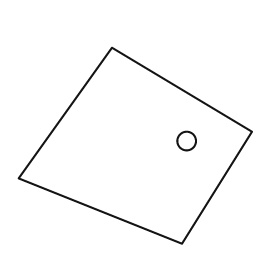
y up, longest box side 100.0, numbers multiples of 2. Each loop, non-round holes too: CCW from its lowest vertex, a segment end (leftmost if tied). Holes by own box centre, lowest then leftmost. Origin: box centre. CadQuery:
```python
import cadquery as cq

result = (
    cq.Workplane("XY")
    .moveTo(20.0, -42.0)
    .lineTo(50.0, 6.0)
    .lineTo(-10.0, 42.0)
    .lineTo(-50.0, -14.0)
    .close()
    .moveTo(22.0, 2.0)
    .circle(4.0)
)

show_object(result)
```